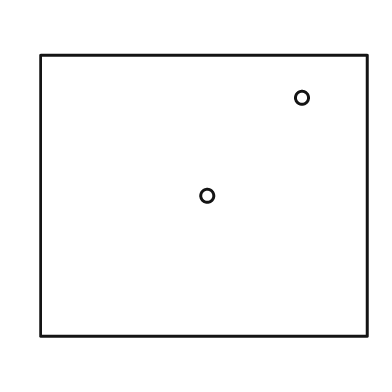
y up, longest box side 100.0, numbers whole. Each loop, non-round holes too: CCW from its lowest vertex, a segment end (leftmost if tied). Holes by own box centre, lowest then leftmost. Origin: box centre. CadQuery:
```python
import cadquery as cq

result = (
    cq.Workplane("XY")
    .moveTo(-50.0, -43.0)
    .lineTo(50.0, -43.0)
    .lineTo(50.0, 43.0)
    .lineTo(-50.0, 43.0)
    .close()
    .moveTo(1.0, 0.0)
    .circle(2.0)
    .moveTo(30.0, 30.0)
    .circle(2.0)
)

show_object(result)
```